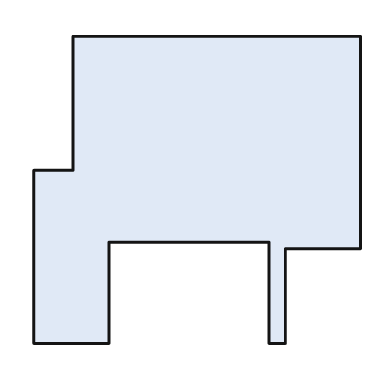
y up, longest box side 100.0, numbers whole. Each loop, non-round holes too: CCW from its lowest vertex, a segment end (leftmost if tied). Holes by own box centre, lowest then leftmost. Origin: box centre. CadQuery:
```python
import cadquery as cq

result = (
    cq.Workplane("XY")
    .moveTo(-50.0, -47.0)
    .lineTo(-27.0, -47.0)
    .lineTo(-27.0, -16.0)
    .lineTo(22.0, -16.0)
    .lineTo(22.0, -47.0)
    .lineTo(27.0, -47.0)
    .lineTo(27.0, -18.0)
    .lineTo(50.0, -18.0)
    .lineTo(50.0, 47.0)
    .lineTo(-38.0, 47.0)
    .lineTo(-38.0, 6.0)
    .lineTo(-50.0, 6.0)
    .close()
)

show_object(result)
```